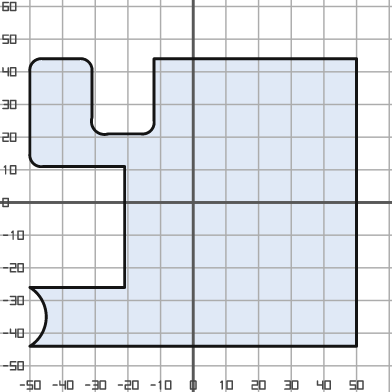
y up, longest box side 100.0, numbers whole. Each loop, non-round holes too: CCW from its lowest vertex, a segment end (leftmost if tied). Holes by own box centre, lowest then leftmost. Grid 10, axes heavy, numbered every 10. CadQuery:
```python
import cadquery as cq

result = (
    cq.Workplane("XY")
    .moveTo(-50.0, -44.0)
    .lineTo(50.0, -44.0)
    .lineTo(50.0, 44.0)
    .lineTo(-12.0, 44.0)
    .lineTo(-12.0, 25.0)
    .threePointArc((-13.0, 22.0), (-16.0, 21.0))
    .lineTo(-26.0, 21.0)
    .threePointArc((-30.0, 22.0), (-31.0, 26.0))
    .lineTo(-31.0, 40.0)
    .threePointArc((-32.0, 43.0), (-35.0, 44.0))
    .lineTo(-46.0, 44.0)
    .threePointArc((-49.0, 43.0), (-50.0, 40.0))
    .lineTo(-50.0, 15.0)
    .threePointArc((-49.0, 12.0), (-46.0, 11.0))
    .lineTo(-21.0, 11.0)
    .lineTo(-21.0, -26.0)
    .lineTo(-50.0, -26.0)
    .threePointArc((-45.0, -35.0), (-50.0, -44.0))
    .close()
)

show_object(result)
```